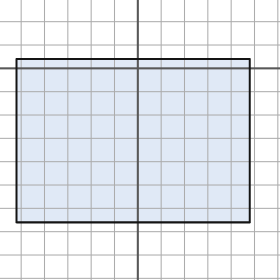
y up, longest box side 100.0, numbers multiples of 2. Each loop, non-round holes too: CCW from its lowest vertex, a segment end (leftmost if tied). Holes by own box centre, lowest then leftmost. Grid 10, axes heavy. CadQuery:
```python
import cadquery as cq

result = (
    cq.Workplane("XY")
    .moveTo(-52.0, -66.0)
    .lineTo(48.0, -66.0)
    .lineTo(48.0, 4.0)
    .lineTo(-52.0, 4.0)
    .close()
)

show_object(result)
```